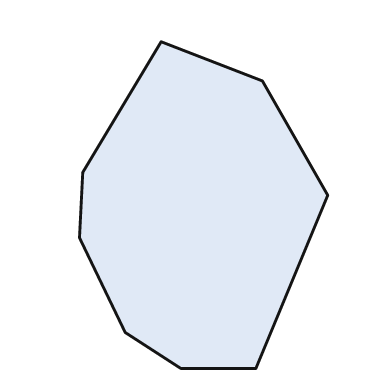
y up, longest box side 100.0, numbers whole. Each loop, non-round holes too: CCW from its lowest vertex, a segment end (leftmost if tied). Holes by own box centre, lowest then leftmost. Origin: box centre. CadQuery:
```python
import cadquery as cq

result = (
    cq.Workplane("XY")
    .moveTo(-7.0, -50.0)
    .lineTo(16.0, -50.0)
    .lineTo(38.0, 3.0)
    .lineTo(18.0, 38.0)
    .lineTo(-13.0, 50.0)
    .lineTo(-37.0, 10.0)
    .lineTo(-38.0, -10.0)
    .lineTo(-24.0, -39.0)
    .close()
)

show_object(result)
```